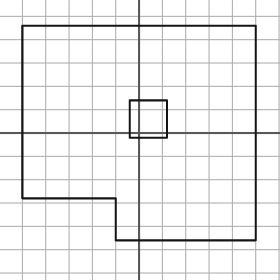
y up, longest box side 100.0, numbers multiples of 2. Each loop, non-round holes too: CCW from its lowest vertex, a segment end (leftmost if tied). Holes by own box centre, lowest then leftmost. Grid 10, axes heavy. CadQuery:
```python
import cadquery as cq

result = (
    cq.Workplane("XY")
    .moveTo(-10.0, -46.0)
    .lineTo(50.0, -46.0)
    .lineTo(50.0, 46.0)
    .lineTo(-50.0, 46.0)
    .lineTo(-50.0, -28.0)
    .lineTo(-10.0, -28.0)
    .close()
    .moveTo(-4.0, -2.0)
    .lineTo(12.0, -2.0)
    .lineTo(12.0, 14.0)
    .lineTo(-4.0, 14.0)
    .close()
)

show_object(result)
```